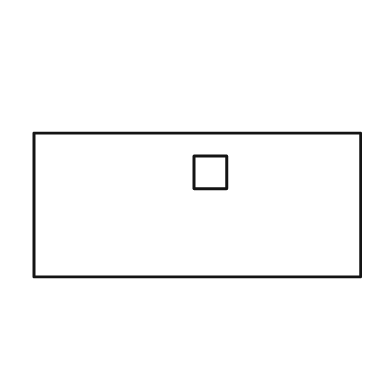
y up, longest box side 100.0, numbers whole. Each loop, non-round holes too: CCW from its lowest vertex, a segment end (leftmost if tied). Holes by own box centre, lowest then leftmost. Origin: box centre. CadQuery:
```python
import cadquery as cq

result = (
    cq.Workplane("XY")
    .moveTo(-50.0, -22.0)
    .lineTo(50.0, -22.0)
    .lineTo(50.0, 22.0)
    .lineTo(-50.0, 22.0)
    .close()
    .moveTo(-1.0, 5.0)
    .lineTo(9.0, 5.0)
    .lineTo(9.0, 15.0)
    .lineTo(-1.0, 15.0)
    .close()
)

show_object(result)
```